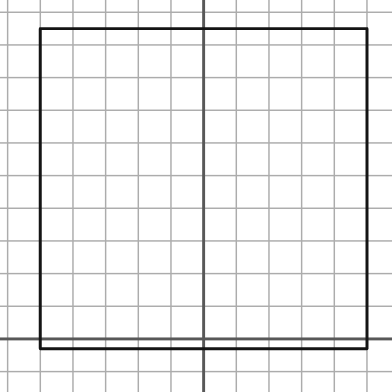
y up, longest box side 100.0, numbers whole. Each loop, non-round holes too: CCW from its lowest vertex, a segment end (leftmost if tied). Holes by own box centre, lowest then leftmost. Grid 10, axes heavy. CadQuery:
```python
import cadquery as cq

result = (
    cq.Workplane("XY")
    .moveTo(-50.0, -3.0)
    .lineTo(50.0, -3.0)
    .lineTo(50.0, 95.0)
    .lineTo(-50.0, 95.0)
    .close()
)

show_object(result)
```